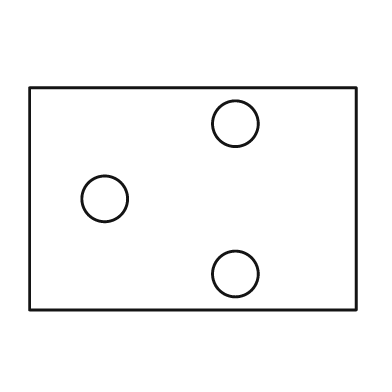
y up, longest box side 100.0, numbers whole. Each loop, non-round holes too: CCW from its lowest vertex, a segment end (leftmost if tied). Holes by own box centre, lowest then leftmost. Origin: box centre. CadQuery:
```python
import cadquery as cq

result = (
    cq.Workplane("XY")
    .moveTo(-50.0, -34.0)
    .lineTo(50.0, -34.0)
    .lineTo(50.0, 34.0)
    .lineTo(-50.0, 34.0)
    .close()
    .moveTo(13.0, -23.0)
    .circle(7.0)
    .moveTo(-27.0, 0.0)
    .circle(7.0)
    .moveTo(13.0, 23.0)
    .circle(7.0)
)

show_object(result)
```